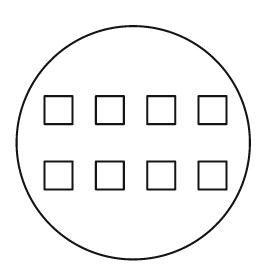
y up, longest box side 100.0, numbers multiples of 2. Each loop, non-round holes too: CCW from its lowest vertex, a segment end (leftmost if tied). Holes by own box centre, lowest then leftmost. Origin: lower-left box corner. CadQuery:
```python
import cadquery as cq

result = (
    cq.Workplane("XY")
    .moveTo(50.0, 50.0)
    .circle(50.0)
    .moveTo(12.0, 30.0)
    .lineTo(24.0, 30.0)
    .lineTo(24.0, 42.0)
    .lineTo(12.0, 42.0)
    .close()
    .moveTo(34.0, 30.0)
    .lineTo(46.0, 30.0)
    .lineTo(46.0, 42.0)
    .lineTo(34.0, 42.0)
    .close()
    .moveTo(56.0, 30.0)
    .lineTo(68.0, 30.0)
    .lineTo(68.0, 42.0)
    .lineTo(56.0, 42.0)
    .close()
    .moveTo(78.0, 30.0)
    .lineTo(90.0, 30.0)
    .lineTo(90.0, 42.0)
    .lineTo(78.0, 42.0)
    .close()
    .moveTo(12.0, 58.0)
    .lineTo(24.0, 58.0)
    .lineTo(24.0, 70.0)
    .lineTo(12.0, 70.0)
    .close()
    .moveTo(34.0, 58.0)
    .lineTo(46.0, 58.0)
    .lineTo(46.0, 70.0)
    .lineTo(34.0, 70.0)
    .close()
    .moveTo(56.0, 58.0)
    .lineTo(68.0, 58.0)
    .lineTo(68.0, 70.0)
    .lineTo(56.0, 70.0)
    .close()
    .moveTo(78.0, 58.0)
    .lineTo(90.0, 58.0)
    .lineTo(90.0, 70.0)
    .lineTo(78.0, 70.0)
    .close()
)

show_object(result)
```